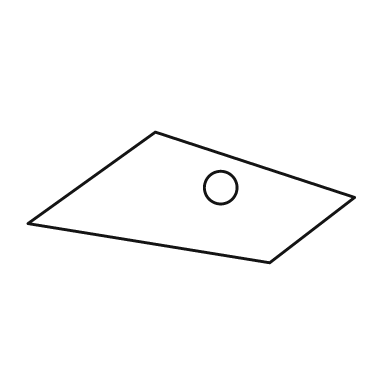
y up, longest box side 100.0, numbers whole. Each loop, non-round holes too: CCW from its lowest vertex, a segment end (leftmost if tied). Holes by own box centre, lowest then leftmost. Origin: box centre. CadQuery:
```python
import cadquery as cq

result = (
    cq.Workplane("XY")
    .moveTo(24.0, -20.0)
    .lineTo(50.0, 0.0)
    .lineTo(-11.0, 20.0)
    .lineTo(-50.0, -8.0)
    .close()
    .moveTo(9.0, 3.0)
    .circle(5.0)
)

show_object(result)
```